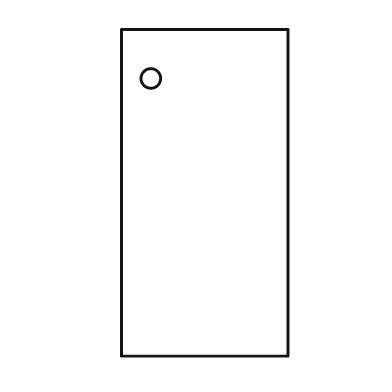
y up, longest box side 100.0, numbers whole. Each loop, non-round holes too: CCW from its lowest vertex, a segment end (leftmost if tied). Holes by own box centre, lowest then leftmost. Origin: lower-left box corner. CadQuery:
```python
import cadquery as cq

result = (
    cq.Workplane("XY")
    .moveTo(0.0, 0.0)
    .lineTo(51.0, 0.0)
    .lineTo(51.0, 100.0)
    .lineTo(0.0, 100.0)
    .close()
    .moveTo(9.0, 85.0)
    .circle(3.0)
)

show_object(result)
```